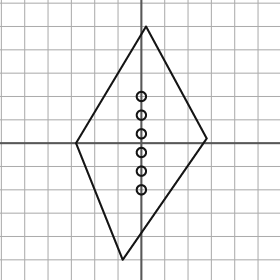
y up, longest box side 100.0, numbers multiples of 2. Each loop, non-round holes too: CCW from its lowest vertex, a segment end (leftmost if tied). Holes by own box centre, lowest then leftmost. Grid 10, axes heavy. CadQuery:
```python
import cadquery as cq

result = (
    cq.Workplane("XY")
    .moveTo(-8.0, -50.0)
    .lineTo(28.0, 2.0)
    .lineTo(2.0, 50.0)
    .lineTo(-28.0, 0.0)
    .close()
    .moveTo(0.0, -20.0)
    .circle(2.0)
    .moveTo(0.0, -12.0)
    .circle(2.0)
    .moveTo(0.0, -4.0)
    .circle(2.0)
    .moveTo(0.0, 4.0)
    .circle(2.0)
    .moveTo(0.0, 12.0)
    .circle(2.0)
    .moveTo(0.0, 20.0)
    .circle(2.0)
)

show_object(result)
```